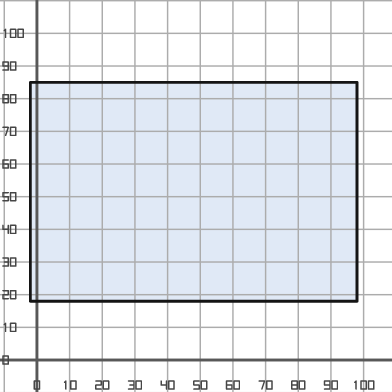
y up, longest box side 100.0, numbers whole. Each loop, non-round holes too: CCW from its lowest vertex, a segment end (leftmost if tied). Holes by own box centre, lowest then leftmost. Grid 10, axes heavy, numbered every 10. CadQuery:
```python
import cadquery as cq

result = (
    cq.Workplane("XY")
    .moveTo(-2.0, 18.0)
    .lineTo(98.0, 18.0)
    .lineTo(98.0, 85.0)
    .lineTo(-2.0, 85.0)
    .close()
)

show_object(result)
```